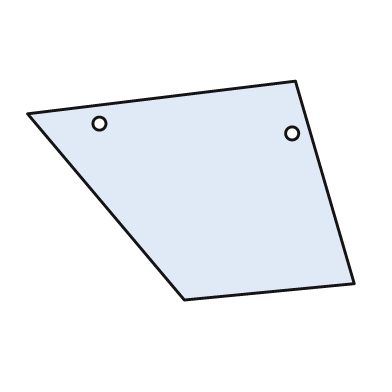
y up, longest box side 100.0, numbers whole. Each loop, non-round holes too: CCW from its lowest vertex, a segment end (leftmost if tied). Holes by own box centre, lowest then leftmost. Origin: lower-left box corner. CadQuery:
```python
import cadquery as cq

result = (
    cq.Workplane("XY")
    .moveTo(48.0, 0.0)
    .lineTo(100.0, 5.0)
    .lineTo(82.0, 67.0)
    .lineTo(0.0, 57.0)
    .close()
    .moveTo(81.0, 51.0)
    .circle(2.0)
    .moveTo(22.0, 54.0)
    .circle(2.0)
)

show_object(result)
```